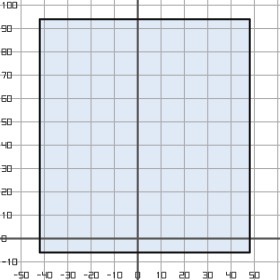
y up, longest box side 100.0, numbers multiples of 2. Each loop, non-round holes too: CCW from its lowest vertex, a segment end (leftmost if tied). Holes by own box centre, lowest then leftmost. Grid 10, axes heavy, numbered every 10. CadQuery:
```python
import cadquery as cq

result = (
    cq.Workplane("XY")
    .moveTo(-42.0, -6.0)
    .lineTo(48.0, -6.0)
    .lineTo(48.0, 94.0)
    .lineTo(-42.0, 94.0)
    .close()
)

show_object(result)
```